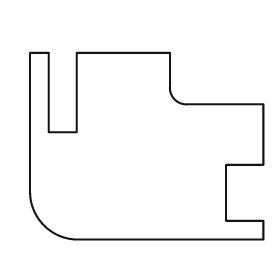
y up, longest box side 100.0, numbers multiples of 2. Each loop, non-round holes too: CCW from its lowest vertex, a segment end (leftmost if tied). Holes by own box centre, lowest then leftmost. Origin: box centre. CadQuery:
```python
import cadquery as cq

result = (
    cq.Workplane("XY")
    .moveTo(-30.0, -40.0)
    .lineTo(50.0, -40.0)
    .lineTo(50.0, -32.0)
    .lineTo(34.0, -32.0)
    .lineTo(34.0, -8.0)
    .lineTo(50.0, -8.0)
    .lineTo(50.0, 18.0)
    .lineTo(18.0, 18.0)
    .threePointArc((12.0, 20.0), (10.0, 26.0))
    .lineTo(10.0, 40.0)
    .lineTo(-30.0, 40.0)
    .lineTo(-30.0, 6.0)
    .lineTo(-42.0, 6.0)
    .lineTo(-42.0, 40.0)
    .lineTo(-50.0, 40.0)
    .lineTo(-50.0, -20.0)
    .threePointArc((-44.0, -34.0), (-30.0, -40.0))
    .close()
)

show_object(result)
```